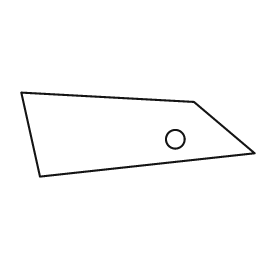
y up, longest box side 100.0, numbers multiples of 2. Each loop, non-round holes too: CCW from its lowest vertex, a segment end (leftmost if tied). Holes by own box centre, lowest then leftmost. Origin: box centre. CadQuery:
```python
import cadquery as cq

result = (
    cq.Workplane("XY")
    .moveTo(-42.0, -18.0)
    .lineTo(50.0, -8.0)
    .lineTo(24.0, 14.0)
    .lineTo(-50.0, 18.0)
    .close()
    .moveTo(16.0, -2.0)
    .circle(4.0)
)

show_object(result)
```